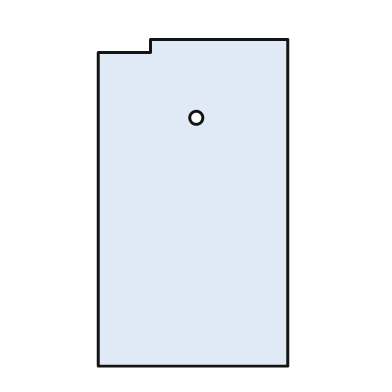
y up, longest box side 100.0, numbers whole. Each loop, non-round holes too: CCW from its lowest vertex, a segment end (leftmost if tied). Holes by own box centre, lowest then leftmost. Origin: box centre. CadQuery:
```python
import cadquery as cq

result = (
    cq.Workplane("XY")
    .moveTo(-29.0, -50.0)
    .lineTo(29.0, -50.0)
    .lineTo(29.0, 50.0)
    .lineTo(-13.0, 50.0)
    .lineTo(-13.0, 46.0)
    .lineTo(-29.0, 46.0)
    .close()
    .moveTo(1.0, 26.0)
    .circle(2.0)
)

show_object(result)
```